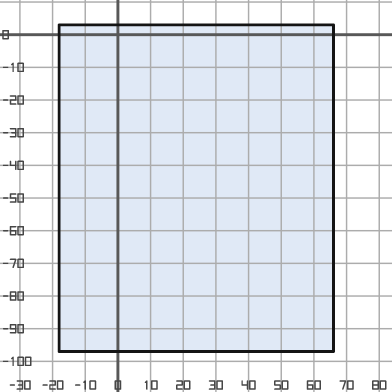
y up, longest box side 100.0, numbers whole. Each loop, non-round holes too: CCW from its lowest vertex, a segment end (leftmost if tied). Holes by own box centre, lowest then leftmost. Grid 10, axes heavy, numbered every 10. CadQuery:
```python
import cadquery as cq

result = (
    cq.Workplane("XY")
    .moveTo(-18.0, -97.0)
    .lineTo(66.0, -97.0)
    .lineTo(66.0, 3.0)
    .lineTo(-18.0, 3.0)
    .close()
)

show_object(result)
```